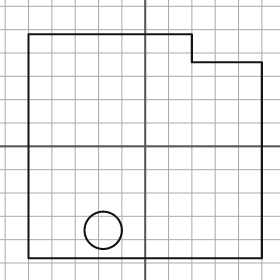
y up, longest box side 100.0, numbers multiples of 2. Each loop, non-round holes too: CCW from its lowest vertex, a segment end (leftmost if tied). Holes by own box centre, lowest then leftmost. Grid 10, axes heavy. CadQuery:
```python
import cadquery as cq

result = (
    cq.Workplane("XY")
    .moveTo(-50.0, -48.0)
    .lineTo(50.0, -48.0)
    .lineTo(50.0, 36.0)
    .lineTo(20.0, 36.0)
    .lineTo(20.0, 48.0)
    .lineTo(-50.0, 48.0)
    .close()
    .moveTo(-18.0, -36.0)
    .circle(8.0)
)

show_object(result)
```